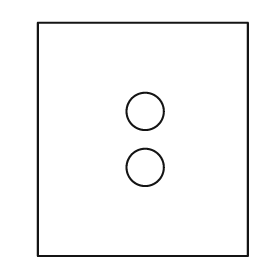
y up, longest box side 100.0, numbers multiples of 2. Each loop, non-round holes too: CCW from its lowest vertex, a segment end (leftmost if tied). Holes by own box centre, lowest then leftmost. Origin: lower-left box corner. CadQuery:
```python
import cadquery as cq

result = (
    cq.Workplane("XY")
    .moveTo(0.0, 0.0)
    .lineTo(90.0, 0.0)
    .lineTo(90.0, 100.0)
    .lineTo(0.0, 100.0)
    .close()
    .moveTo(46.0, 38.0)
    .circle(8.0)
    .moveTo(46.0, 62.0)
    .circle(8.0)
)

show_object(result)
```